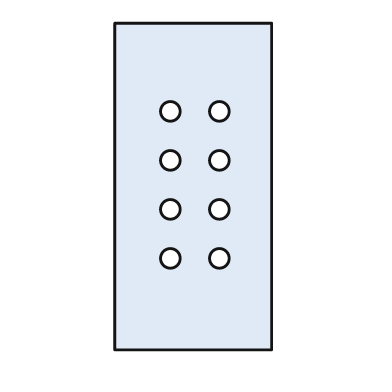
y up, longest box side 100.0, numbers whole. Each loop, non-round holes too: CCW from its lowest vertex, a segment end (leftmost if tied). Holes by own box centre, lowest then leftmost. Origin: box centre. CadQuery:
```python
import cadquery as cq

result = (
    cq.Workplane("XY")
    .moveTo(-24.0, -50.0)
    .lineTo(24.0, -50.0)
    .lineTo(24.0, 50.0)
    .lineTo(-24.0, 50.0)
    .close()
    .moveTo(-7.0, -22.0)
    .circle(3.0)
    .moveTo(8.0, -22.0)
    .circle(3.0)
    .moveTo(-7.0, -7.0)
    .circle(3.0)
    .moveTo(8.0, -7.0)
    .circle(3.0)
    .moveTo(-7.0, 8.0)
    .circle(3.0)
    .moveTo(8.0, 8.0)
    .circle(3.0)
    .moveTo(-7.0, 23.0)
    .circle(3.0)
    .moveTo(8.0, 23.0)
    .circle(3.0)
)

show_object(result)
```